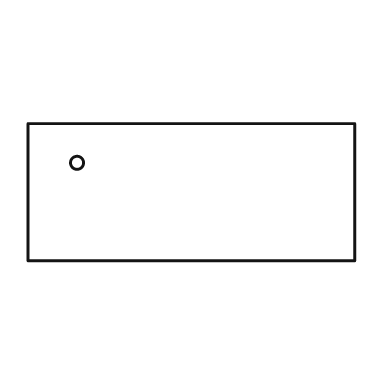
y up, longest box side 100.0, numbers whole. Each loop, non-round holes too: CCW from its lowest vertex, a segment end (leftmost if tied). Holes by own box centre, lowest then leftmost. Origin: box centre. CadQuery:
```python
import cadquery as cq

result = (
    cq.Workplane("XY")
    .moveTo(-50.0, -21.0)
    .lineTo(50.0, -21.0)
    .lineTo(50.0, 21.0)
    .lineTo(-50.0, 21.0)
    .close()
    .moveTo(-35.0, 9.0)
    .circle(2.0)
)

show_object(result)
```